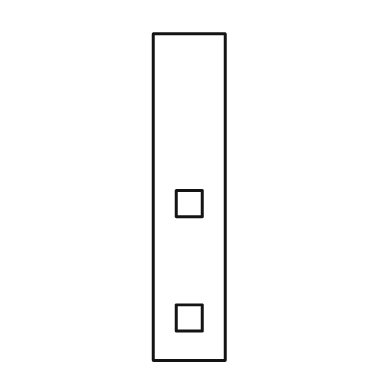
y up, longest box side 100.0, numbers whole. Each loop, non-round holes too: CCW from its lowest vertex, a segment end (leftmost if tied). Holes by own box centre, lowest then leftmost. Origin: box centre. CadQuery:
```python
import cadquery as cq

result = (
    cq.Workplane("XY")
    .moveTo(-11.0, -50.0)
    .lineTo(11.0, -50.0)
    .lineTo(11.0, 50.0)
    .lineTo(-11.0, 50.0)
    .close()
    .moveTo(-4.0, -41.0)
    .lineTo(4.0, -41.0)
    .lineTo(4.0, -33.0)
    .lineTo(-4.0, -33.0)
    .close()
    .moveTo(-4.0, -6.0)
    .lineTo(4.0, -6.0)
    .lineTo(4.0, 2.0)
    .lineTo(-4.0, 2.0)
    .close()
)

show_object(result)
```